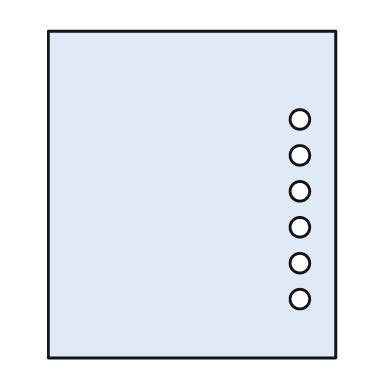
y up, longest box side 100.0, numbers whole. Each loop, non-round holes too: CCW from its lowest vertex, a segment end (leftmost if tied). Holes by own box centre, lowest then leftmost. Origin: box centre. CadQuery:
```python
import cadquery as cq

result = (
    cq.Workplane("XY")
    .moveTo(-44.0, -50.0)
    .lineTo(44.0, -50.0)
    .lineTo(44.0, 50.0)
    .lineTo(-44.0, 50.0)
    .close()
    .moveTo(33.0, -32.0)
    .circle(3.0)
    .moveTo(33.0, -21.0)
    .circle(3.0)
    .moveTo(33.0, -10.0)
    .circle(3.0)
    .moveTo(33.0, 1.0)
    .circle(3.0)
    .moveTo(33.0, 12.0)
    .circle(3.0)
    .moveTo(33.0, 23.0)
    .circle(3.0)
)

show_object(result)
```